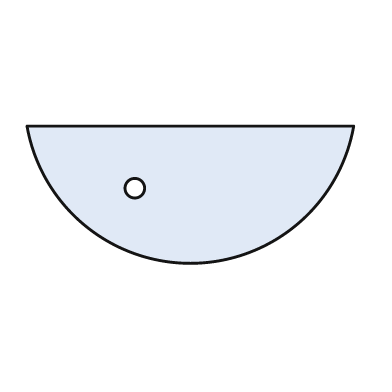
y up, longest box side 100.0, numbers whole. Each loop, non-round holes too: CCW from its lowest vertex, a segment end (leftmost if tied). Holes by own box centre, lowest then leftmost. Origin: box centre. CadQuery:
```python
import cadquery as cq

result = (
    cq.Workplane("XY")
    .moveTo(-50.0, 21.0)
    .threePointArc((0.0, -21.0), (50.0, 21.0))
    .close()
    .moveTo(-17.0, 2.0)
    .circle(3.0)
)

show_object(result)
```